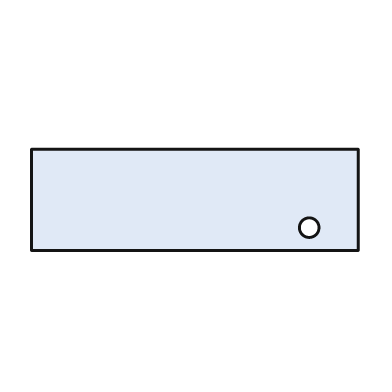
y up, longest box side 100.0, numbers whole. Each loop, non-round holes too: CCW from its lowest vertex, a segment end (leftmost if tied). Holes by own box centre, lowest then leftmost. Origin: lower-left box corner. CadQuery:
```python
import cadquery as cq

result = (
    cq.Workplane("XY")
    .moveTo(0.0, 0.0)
    .lineTo(100.0, 0.0)
    .lineTo(100.0, 31.0)
    .lineTo(0.0, 31.0)
    .close()
    .moveTo(85.0, 7.0)
    .circle(3.0)
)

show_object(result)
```